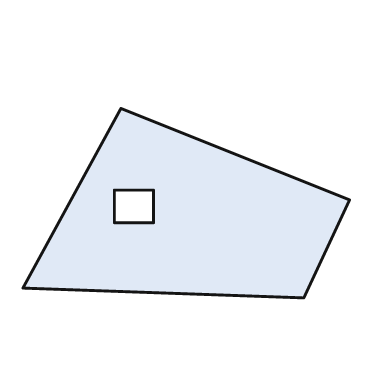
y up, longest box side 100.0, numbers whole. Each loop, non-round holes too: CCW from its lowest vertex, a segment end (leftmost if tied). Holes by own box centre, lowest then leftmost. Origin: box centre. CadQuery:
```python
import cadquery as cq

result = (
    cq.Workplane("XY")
    .moveTo(36.0, -29.0)
    .lineTo(50.0, 1.0)
    .lineTo(-20.0, 29.0)
    .lineTo(-50.0, -26.0)
    .close()
    .moveTo(-22.0, -6.0)
    .lineTo(-10.0, -6.0)
    .lineTo(-10.0, 4.0)
    .lineTo(-22.0, 4.0)
    .close()
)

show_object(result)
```